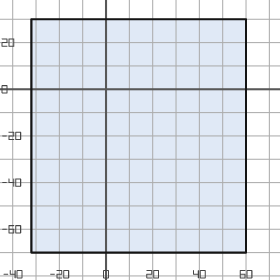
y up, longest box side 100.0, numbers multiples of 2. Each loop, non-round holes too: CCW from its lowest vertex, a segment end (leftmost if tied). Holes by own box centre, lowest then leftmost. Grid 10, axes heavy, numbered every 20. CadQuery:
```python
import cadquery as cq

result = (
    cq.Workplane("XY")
    .moveTo(-32.0, -70.0)
    .lineTo(60.0, -70.0)
    .lineTo(60.0, 30.0)
    .lineTo(-32.0, 30.0)
    .close()
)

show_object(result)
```